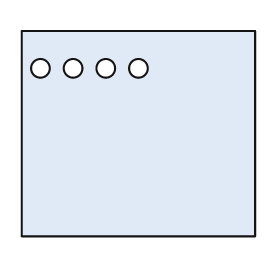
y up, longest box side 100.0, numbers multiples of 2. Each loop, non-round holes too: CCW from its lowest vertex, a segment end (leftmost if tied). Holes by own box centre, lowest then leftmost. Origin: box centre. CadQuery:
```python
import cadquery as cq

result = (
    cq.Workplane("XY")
    .moveTo(-50.0, -44.0)
    .lineTo(50.0, -44.0)
    .lineTo(50.0, 44.0)
    .lineTo(-50.0, 44.0)
    .close()
    .moveTo(-42.0, 28.0)
    .circle(4.0)
    .moveTo(-28.0, 28.0)
    .circle(4.0)
    .moveTo(-14.0, 28.0)
    .circle(4.0)
    .moveTo(0.0, 28.0)
    .circle(4.0)
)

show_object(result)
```